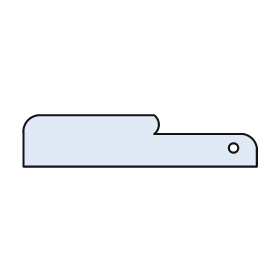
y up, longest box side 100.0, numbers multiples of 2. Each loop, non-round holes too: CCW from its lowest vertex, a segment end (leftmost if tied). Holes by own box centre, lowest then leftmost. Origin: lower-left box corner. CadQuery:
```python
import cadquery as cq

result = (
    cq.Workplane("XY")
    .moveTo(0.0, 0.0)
    .lineTo(100.0, 0.0)
    .lineTo(100.0, 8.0)
    .threePointArc((98.0, 12.0), (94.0, 14.0))
    .lineTo(56.0, 14.0)
    .threePointArc((58.0, 18.0), (56.0, 22.0))
    .lineTo(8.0, 22.0)
    .threePointArc((2.0, 20.0), (0.0, 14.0))
    .close()
    .moveTo(90.0, 8.0)
    .circle(2.0)
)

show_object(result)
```